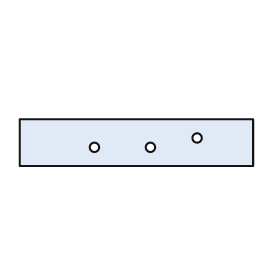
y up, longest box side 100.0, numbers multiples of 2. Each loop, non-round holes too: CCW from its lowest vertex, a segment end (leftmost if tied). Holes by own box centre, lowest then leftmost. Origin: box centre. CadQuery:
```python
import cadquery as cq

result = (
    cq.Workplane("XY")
    .moveTo(-50.0, -10.0)
    .lineTo(50.0, -10.0)
    .lineTo(50.0, 10.0)
    .lineTo(-50.0, 10.0)
    .close()
    .moveTo(-18.0, -2.0)
    .circle(2.0)
    .moveTo(6.0, -2.0)
    .circle(2.0)
    .moveTo(26.0, 2.0)
    .circle(2.0)
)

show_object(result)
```